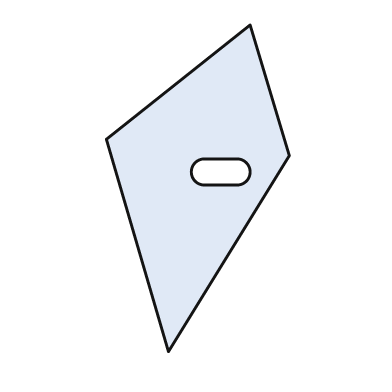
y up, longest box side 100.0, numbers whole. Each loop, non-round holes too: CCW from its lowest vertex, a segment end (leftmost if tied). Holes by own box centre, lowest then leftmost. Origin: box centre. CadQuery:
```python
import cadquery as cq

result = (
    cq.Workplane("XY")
    .moveTo(-9.0, -50.0)
    .lineTo(28.0, 10.0)
    .lineTo(16.0, 50.0)
    .lineTo(-28.0, 15.0)
    .close()
    .moveTo(2.0, 1.0)
    .lineTo(12.0, 1.0)
    .threePointArc((16.0, 5.0), (12.0, 9.0))
    .lineTo(2.0, 9.0)
    .threePointArc((-2.0, 5.0), (2.0, 1.0))
    .close()
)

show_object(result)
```